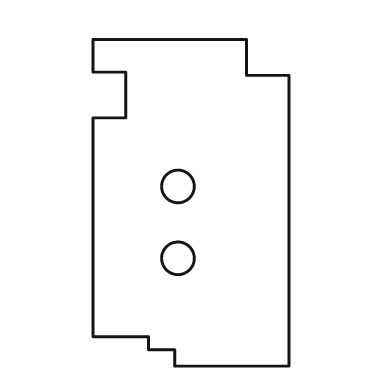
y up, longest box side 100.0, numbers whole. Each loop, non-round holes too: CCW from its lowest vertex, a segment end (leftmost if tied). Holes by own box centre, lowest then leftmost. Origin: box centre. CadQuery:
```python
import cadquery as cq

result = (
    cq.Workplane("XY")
    .moveTo(-5.0, -50.0)
    .lineTo(30.0, -50.0)
    .lineTo(30.0, 39.0)
    .lineTo(17.0, 39.0)
    .lineTo(17.0, 50.0)
    .lineTo(-30.0, 50.0)
    .lineTo(-30.0, 40.0)
    .lineTo(-20.0, 40.0)
    .lineTo(-20.0, 26.0)
    .lineTo(-30.0, 26.0)
    .lineTo(-30.0, -41.0)
    .lineTo(-13.0, -41.0)
    .lineTo(-13.0, -45.0)
    .lineTo(-5.0, -45.0)
    .close()
    .moveTo(-4.0, -17.0)
    .circle(5.0)
    .moveTo(-4.0, 5.0)
    .circle(5.0)
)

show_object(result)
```